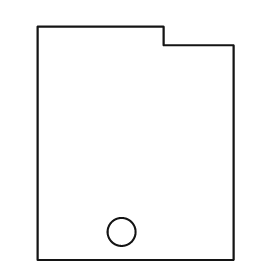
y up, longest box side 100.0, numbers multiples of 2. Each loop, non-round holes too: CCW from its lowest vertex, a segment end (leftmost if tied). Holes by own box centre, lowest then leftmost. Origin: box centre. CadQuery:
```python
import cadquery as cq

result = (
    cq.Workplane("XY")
    .moveTo(-42.0, -50.0)
    .lineTo(42.0, -50.0)
    .lineTo(42.0, 42.0)
    .lineTo(12.0, 42.0)
    .lineTo(12.0, 50.0)
    .lineTo(-42.0, 50.0)
    .close()
    .moveTo(-6.0, -38.0)
    .circle(6.0)
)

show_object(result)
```